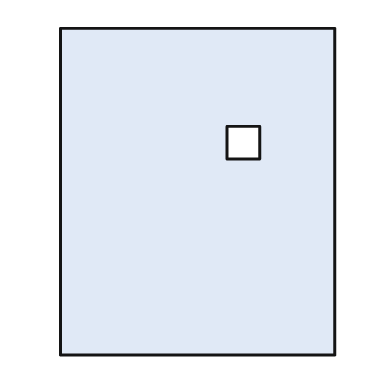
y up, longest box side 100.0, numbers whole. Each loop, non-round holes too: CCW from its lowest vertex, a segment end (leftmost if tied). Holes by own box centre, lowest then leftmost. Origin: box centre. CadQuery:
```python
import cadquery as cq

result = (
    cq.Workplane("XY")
    .moveTo(-42.0, -50.0)
    .lineTo(42.0, -50.0)
    .lineTo(42.0, 50.0)
    .lineTo(-42.0, 50.0)
    .close()
    .moveTo(9.0, 10.0)
    .lineTo(19.0, 10.0)
    .lineTo(19.0, 20.0)
    .lineTo(9.0, 20.0)
    .close()
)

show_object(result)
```